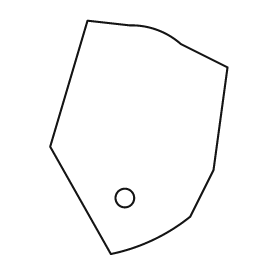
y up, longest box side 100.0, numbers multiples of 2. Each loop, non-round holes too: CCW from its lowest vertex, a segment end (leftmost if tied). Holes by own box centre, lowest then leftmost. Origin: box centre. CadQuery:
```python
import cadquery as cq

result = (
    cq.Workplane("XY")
    .moveTo(-12.0, -50.0)
    .threePointArc((6.0, -44.0), (22.0, -34.0))
    .lineTo(32.0, -14.0)
    .lineTo(38.0, 30.0)
    .lineTo(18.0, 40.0)
    .threePointArc((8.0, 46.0), (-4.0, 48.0))
    .lineTo(-22.0, 50.0)
    .lineTo(-38.0, -4.0)
    .close()
    .moveTo(-6.0, -26.0)
    .circle(4.0)
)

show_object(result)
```